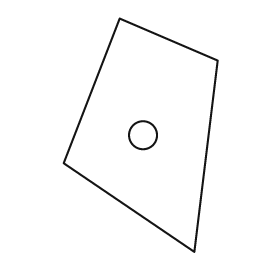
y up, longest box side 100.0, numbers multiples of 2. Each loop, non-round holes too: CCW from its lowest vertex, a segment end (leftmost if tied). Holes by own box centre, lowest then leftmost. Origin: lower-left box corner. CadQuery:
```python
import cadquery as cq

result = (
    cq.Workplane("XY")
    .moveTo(56.0, 0.0)
    .lineTo(66.0, 82.0)
    .lineTo(24.0, 100.0)
    .lineTo(0.0, 38.0)
    .close()
    .moveTo(34.0, 50.0)
    .circle(6.0)
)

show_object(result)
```